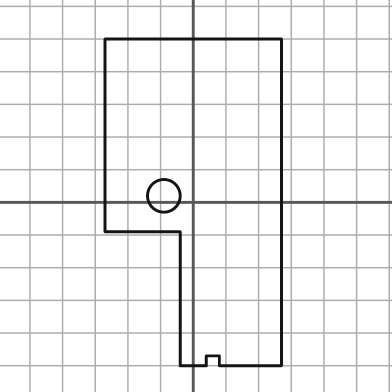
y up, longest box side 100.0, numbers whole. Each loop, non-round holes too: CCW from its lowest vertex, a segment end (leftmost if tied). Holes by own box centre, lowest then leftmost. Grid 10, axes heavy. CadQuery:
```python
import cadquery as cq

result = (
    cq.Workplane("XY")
    .moveTo(-4.0, -50.0)
    .lineTo(4.0, -50.0)
    .lineTo(4.0, -47.0)
    .lineTo(8.0, -47.0)
    .lineTo(8.0, -50.0)
    .lineTo(27.0, -50.0)
    .lineTo(27.0, 50.0)
    .lineTo(-27.0, 50.0)
    .lineTo(-27.0, -9.0)
    .lineTo(-4.0, -9.0)
    .close()
    .moveTo(-9.0, 2.0)
    .circle(5.0)
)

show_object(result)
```